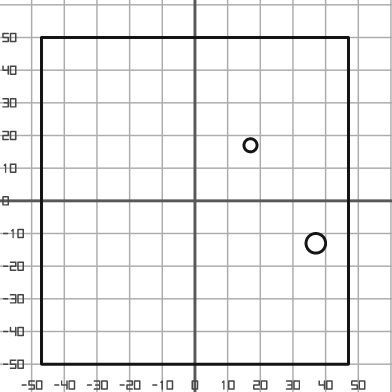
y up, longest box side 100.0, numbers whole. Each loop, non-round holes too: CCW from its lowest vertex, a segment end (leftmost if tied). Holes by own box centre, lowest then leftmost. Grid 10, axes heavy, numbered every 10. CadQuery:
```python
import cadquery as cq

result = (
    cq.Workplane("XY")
    .moveTo(-47.0, -50.0)
    .lineTo(47.0, -50.0)
    .lineTo(47.0, 50.0)
    .lineTo(-47.0, 50.0)
    .close()
    .moveTo(37.0, -13.0)
    .circle(3.0)
    .moveTo(17.0, 17.0)
    .circle(2.0)
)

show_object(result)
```